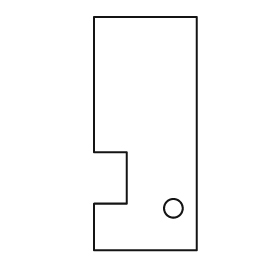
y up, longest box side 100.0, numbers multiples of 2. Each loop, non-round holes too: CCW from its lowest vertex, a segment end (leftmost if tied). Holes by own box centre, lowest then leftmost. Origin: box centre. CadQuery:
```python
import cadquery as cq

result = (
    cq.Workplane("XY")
    .moveTo(-22.0, -50.0)
    .lineTo(22.0, -50.0)
    .lineTo(22.0, 50.0)
    .lineTo(-22.0, 50.0)
    .lineTo(-22.0, -8.0)
    .lineTo(-8.0, -8.0)
    .lineTo(-8.0, -30.0)
    .lineTo(-22.0, -30.0)
    .close()
    .moveTo(12.0, -32.0)
    .circle(4.0)
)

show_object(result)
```